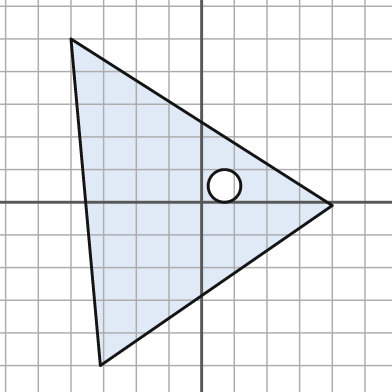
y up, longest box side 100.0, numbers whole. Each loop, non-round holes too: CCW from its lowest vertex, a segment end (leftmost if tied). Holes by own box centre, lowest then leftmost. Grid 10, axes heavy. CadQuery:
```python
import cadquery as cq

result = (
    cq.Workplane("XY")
    .moveTo(-31.0, -50.0)
    .lineTo(40.0, -1.0)
    .lineTo(-40.0, 50.0)
    .close()
    .moveTo(7.0, 5.0)
    .circle(5.0)
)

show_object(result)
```